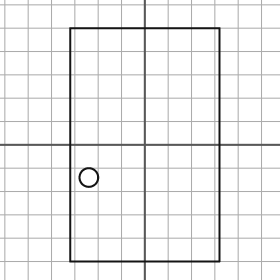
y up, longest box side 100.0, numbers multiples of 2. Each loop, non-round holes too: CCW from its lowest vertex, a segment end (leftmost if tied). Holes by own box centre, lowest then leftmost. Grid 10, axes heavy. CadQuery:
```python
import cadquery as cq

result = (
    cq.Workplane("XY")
    .moveTo(-32.0, -50.0)
    .lineTo(32.0, -50.0)
    .lineTo(32.0, 50.0)
    .lineTo(-32.0, 50.0)
    .close()
    .moveTo(-24.0, -14.0)
    .circle(4.0)
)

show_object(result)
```